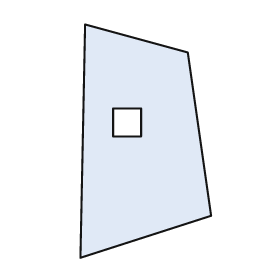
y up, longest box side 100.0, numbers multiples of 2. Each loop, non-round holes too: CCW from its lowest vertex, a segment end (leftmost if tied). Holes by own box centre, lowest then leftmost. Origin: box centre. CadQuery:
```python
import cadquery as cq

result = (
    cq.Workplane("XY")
    .moveTo(-28.0, -50.0)
    .lineTo(28.0, -32.0)
    .lineTo(18.0, 38.0)
    .lineTo(-26.0, 50.0)
    .close()
    .moveTo(-14.0, 2.0)
    .lineTo(-2.0, 2.0)
    .lineTo(-2.0, 14.0)
    .lineTo(-14.0, 14.0)
    .close()
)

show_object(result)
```